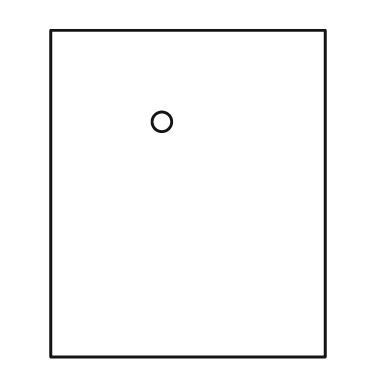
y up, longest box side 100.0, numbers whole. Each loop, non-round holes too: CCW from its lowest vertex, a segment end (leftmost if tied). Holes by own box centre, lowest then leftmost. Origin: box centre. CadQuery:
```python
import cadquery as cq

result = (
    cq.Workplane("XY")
    .moveTo(-42.0, -50.0)
    .lineTo(42.0, -50.0)
    .lineTo(42.0, 50.0)
    .lineTo(-42.0, 50.0)
    .close()
    .moveTo(-8.0, 22.0)
    .circle(3.0)
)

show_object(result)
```